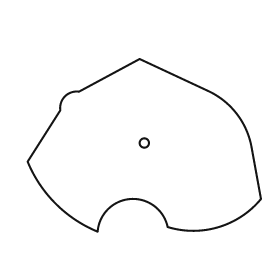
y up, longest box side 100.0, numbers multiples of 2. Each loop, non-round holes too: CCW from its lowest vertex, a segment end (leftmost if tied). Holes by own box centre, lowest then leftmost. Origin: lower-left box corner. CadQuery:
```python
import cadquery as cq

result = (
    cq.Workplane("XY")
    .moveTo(30.0, 0.0)
    .threePointArc((44.0, 14.0), (60.0, 2.0))
    .threePointArc((82.0, 2.0), (100.0, 14.0))
    .lineTo(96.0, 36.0)
    .threePointArc((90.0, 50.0), (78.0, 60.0))
    .lineTo(48.0, 74.0)
    .lineTo(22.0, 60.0)
    .threePointArc((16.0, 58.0), (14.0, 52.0))
    .lineTo(0.0, 30.0)
    .threePointArc((12.0, 12.0), (30.0, 0.0))
    .close()
    .moveTo(50.0, 38.0)
    .circle(2.0)
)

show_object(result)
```